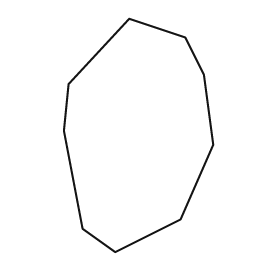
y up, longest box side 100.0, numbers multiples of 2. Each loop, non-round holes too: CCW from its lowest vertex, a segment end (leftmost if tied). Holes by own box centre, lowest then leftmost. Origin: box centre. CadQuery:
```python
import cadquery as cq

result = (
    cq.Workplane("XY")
    .moveTo(-10.0, -50.0)
    .lineTo(18.0, -36.0)
    .lineTo(32.0, -4.0)
    .lineTo(28.0, 26.0)
    .lineTo(20.0, 42.0)
    .lineTo(-4.0, 50.0)
    .lineTo(-30.0, 22.0)
    .lineTo(-32.0, 2.0)
    .lineTo(-24.0, -40.0)
    .close()
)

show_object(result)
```